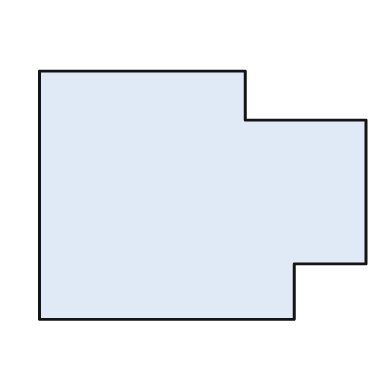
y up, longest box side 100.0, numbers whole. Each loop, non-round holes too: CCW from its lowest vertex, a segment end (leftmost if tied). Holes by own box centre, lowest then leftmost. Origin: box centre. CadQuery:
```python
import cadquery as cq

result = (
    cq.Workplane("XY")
    .moveTo(-50.0, -38.0)
    .lineTo(28.0, -38.0)
    .lineTo(28.0, -21.0)
    .lineTo(50.0, -21.0)
    .lineTo(50.0, 23.0)
    .lineTo(13.0, 23.0)
    .lineTo(13.0, 38.0)
    .lineTo(-50.0, 38.0)
    .close()
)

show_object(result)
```